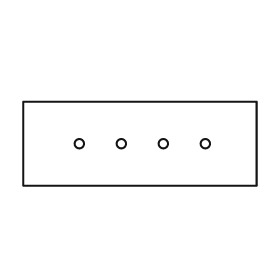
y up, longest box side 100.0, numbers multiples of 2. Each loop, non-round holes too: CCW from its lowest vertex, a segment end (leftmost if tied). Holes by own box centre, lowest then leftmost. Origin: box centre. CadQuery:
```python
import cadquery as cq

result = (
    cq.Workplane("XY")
    .moveTo(-50.0, -18.0)
    .lineTo(50.0, -18.0)
    .lineTo(50.0, 18.0)
    .lineTo(-50.0, 18.0)
    .close()
    .moveTo(-26.0, 0.0)
    .circle(2.0)
    .moveTo(-8.0, 0.0)
    .circle(2.0)
    .moveTo(10.0, 0.0)
    .circle(2.0)
    .moveTo(28.0, 0.0)
    .circle(2.0)
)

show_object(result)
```